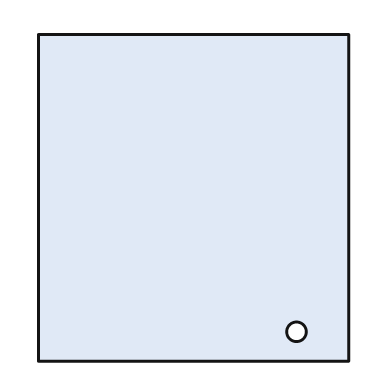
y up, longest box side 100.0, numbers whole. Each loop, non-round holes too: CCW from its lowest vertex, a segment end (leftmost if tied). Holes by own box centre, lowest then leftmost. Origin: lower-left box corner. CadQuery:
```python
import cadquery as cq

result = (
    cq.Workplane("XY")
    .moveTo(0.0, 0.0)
    .lineTo(95.0, 0.0)
    .lineTo(95.0, 100.0)
    .lineTo(0.0, 100.0)
    .close()
    .moveTo(79.0, 9.0)
    .circle(3.0)
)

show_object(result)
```